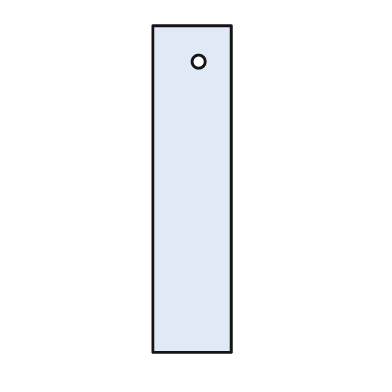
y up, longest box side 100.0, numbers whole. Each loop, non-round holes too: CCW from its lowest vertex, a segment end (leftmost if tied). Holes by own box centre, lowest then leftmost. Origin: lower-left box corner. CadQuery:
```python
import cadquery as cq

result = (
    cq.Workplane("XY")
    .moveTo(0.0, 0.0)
    .lineTo(24.0, 0.0)
    .lineTo(24.0, 100.0)
    .lineTo(0.0, 100.0)
    .close()
    .moveTo(14.0, 89.0)
    .circle(2.0)
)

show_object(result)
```